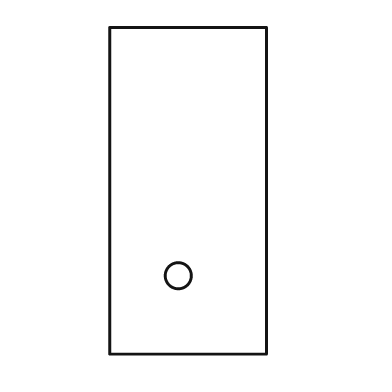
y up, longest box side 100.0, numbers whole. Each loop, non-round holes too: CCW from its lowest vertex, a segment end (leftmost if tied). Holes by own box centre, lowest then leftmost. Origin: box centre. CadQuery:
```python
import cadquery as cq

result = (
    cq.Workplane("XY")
    .moveTo(-24.0, -50.0)
    .lineTo(24.0, -50.0)
    .lineTo(24.0, 50.0)
    .lineTo(-24.0, 50.0)
    .close()
    .moveTo(-3.0, -26.0)
    .circle(4.0)
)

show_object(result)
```